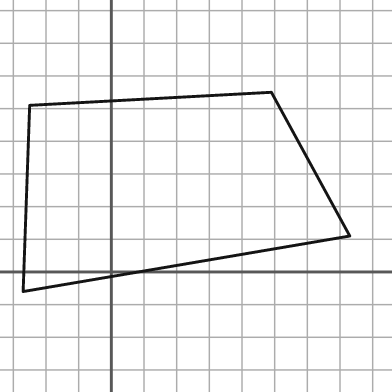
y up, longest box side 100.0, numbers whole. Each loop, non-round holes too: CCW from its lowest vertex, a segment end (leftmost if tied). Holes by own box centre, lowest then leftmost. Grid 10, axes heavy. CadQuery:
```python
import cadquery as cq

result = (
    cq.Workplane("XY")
    .moveTo(-27.0, -6.0)
    .lineTo(73.0, 11.0)
    .lineTo(49.0, 55.0)
    .lineTo(-25.0, 51.0)
    .close()
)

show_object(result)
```